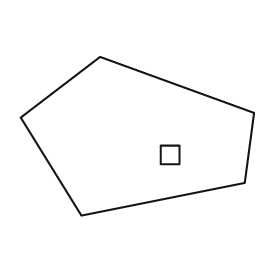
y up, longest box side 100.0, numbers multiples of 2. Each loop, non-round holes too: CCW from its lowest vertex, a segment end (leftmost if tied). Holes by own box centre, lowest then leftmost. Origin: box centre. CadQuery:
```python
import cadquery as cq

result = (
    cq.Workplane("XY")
    .moveTo(-24.0, -34.0)
    .lineTo(46.0, -20.0)
    .lineTo(50.0, 10.0)
    .lineTo(-16.0, 34.0)
    .lineTo(-50.0, 8.0)
    .close()
    .moveTo(10.0, -12.0)
    .lineTo(18.0, -12.0)
    .lineTo(18.0, -4.0)
    .lineTo(10.0, -4.0)
    .close()
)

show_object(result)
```